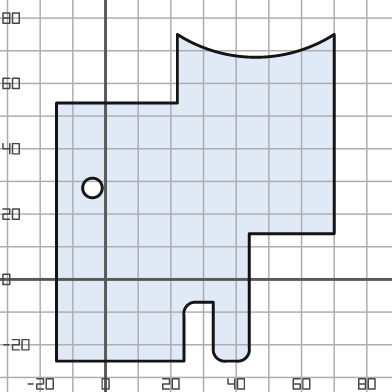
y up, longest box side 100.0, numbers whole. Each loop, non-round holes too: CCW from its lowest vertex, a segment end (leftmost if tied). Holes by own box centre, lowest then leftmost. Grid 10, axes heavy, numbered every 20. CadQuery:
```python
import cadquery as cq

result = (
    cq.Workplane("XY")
    .moveTo(-15.0, -25.0)
    .lineTo(24.0, -25.0)
    .lineTo(24.0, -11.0)
    .threePointArc((25.0, -8.0), (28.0, -7.0))
    .lineTo(33.0, -7.0)
    .lineTo(33.0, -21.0)
    .threePointArc((34.0, -24.0), (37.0, -25.0))
    .lineTo(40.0, -25.0)
    .threePointArc((43.0, -24.0), (44.0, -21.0))
    .lineTo(44.0, 14.0)
    .lineTo(70.0, 14.0)
    .lineTo(70.0, 75.0)
    .threePointArc((46.0, 68.0), (22.0, 75.0))
    .lineTo(22.0, 54.0)
    .lineTo(-15.0, 54.0)
    .close()
    .moveTo(-4.0, 28.0)
    .circle(3.0)
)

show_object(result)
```